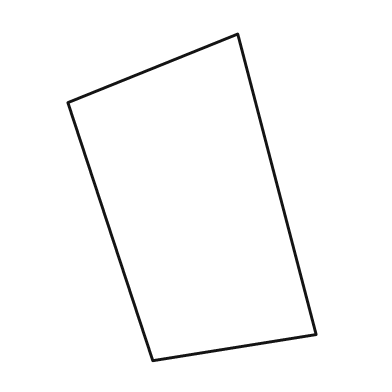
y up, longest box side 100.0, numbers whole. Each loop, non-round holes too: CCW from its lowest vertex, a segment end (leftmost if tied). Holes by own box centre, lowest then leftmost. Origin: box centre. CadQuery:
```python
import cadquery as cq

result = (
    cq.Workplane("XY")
    .moveTo(-12.0, -50.0)
    .lineTo(38.0, -42.0)
    .lineTo(14.0, 50.0)
    .lineTo(-38.0, 29.0)
    .close()
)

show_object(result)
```